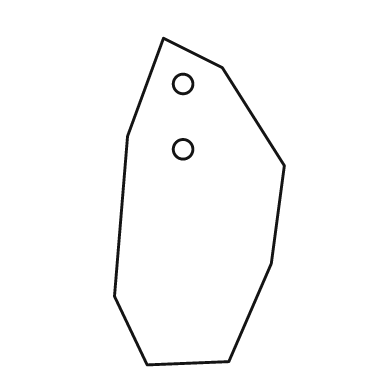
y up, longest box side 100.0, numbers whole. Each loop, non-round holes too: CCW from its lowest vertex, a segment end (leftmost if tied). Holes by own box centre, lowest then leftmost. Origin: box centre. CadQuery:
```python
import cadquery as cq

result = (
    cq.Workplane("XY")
    .moveTo(-16.0, -50.0)
    .lineTo(9.0, -49.0)
    .lineTo(22.0, -19.0)
    .lineTo(26.0, 11.0)
    .lineTo(7.0, 41.0)
    .lineTo(-11.0, 50.0)
    .lineTo(-22.0, 20.0)
    .lineTo(-26.0, -29.0)
    .close()
    .moveTo(-5.0, 16.0)
    .circle(3.0)
    .moveTo(-5.0, 36.0)
    .circle(3.0)
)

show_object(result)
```